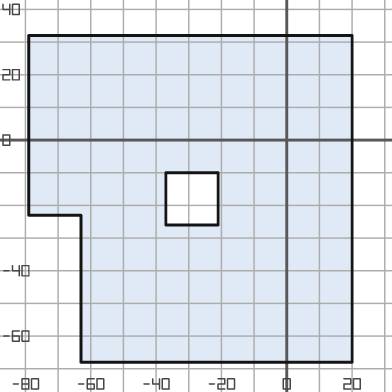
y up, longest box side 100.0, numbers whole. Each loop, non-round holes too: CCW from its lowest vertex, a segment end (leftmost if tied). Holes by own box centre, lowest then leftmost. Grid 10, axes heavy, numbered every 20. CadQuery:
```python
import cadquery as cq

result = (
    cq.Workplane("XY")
    .moveTo(-63.0, -68.0)
    .lineTo(20.0, -68.0)
    .lineTo(20.0, 32.0)
    .lineTo(-79.0, 32.0)
    .lineTo(-79.0, -23.0)
    .lineTo(-63.0, -23.0)
    .close()
    .moveTo(-37.0, -26.0)
    .lineTo(-21.0, -26.0)
    .lineTo(-21.0, -10.0)
    .lineTo(-37.0, -10.0)
    .close()
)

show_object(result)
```